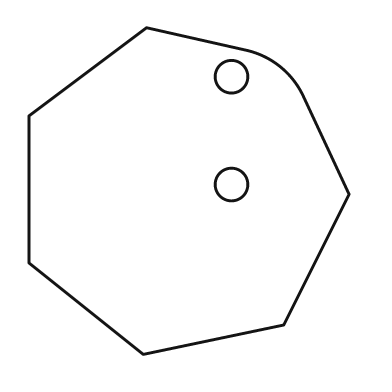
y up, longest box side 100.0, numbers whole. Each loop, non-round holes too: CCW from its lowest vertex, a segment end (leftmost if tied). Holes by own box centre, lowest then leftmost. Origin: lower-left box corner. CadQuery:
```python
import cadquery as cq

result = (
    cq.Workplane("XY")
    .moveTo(35.0, 0.0)
    .lineTo(78.0, 9.0)
    .lineTo(98.0, 49.0)
    .lineTo(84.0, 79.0)
    .threePointArc((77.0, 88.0), (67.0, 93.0))
    .lineTo(36.0, 100.0)
    .lineTo(0.0, 73.0)
    .lineTo(0.0, 28.0)
    .close()
    .moveTo(62.0, 52.0)
    .circle(5.0)
    .moveTo(62.0, 85.0)
    .circle(5.0)
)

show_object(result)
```